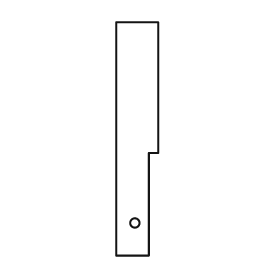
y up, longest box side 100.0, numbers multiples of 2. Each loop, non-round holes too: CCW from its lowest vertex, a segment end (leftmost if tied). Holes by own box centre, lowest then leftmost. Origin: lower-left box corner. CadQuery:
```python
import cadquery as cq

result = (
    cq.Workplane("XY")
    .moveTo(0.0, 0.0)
    .lineTo(14.0, 0.0)
    .lineTo(14.0, 44.0)
    .lineTo(18.0, 44.0)
    .lineTo(18.0, 100.0)
    .lineTo(0.0, 100.0)
    .close()
    .moveTo(8.0, 14.0)
    .circle(2.0)
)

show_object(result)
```